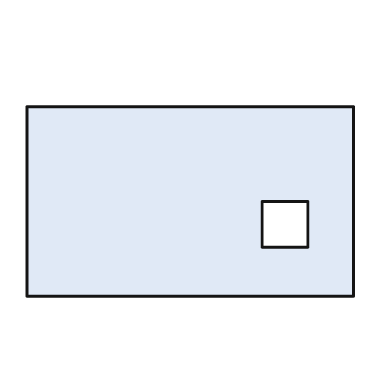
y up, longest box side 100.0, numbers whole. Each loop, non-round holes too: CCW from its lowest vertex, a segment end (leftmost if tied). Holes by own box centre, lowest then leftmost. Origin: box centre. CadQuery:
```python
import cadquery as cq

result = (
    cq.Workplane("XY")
    .moveTo(-50.0, -29.0)
    .lineTo(50.0, -29.0)
    .lineTo(50.0, 29.0)
    .lineTo(-50.0, 29.0)
    .close()
    .moveTo(22.0, -14.0)
    .lineTo(36.0, -14.0)
    .lineTo(36.0, 0.0)
    .lineTo(22.0, 0.0)
    .close()
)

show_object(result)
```